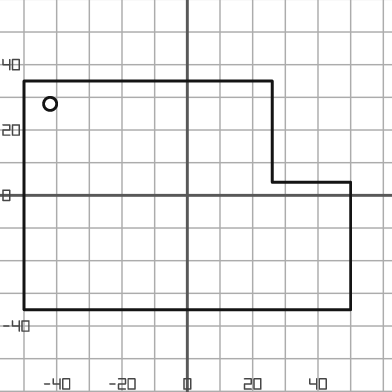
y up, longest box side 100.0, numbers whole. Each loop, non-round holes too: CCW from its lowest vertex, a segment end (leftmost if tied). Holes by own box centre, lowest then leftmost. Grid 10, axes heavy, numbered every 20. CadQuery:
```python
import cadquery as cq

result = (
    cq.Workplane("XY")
    .moveTo(-50.0, -35.0)
    .lineTo(50.0, -35.0)
    .lineTo(50.0, 4.0)
    .lineTo(26.0, 4.0)
    .lineTo(26.0, 35.0)
    .lineTo(-50.0, 35.0)
    .close()
    .moveTo(-42.0, 28.0)
    .circle(2.0)
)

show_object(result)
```